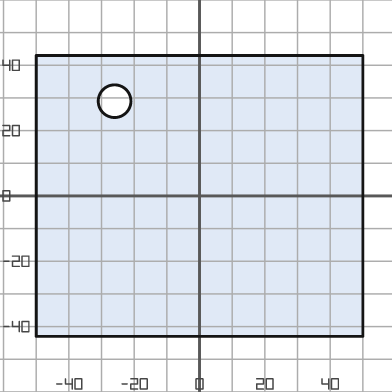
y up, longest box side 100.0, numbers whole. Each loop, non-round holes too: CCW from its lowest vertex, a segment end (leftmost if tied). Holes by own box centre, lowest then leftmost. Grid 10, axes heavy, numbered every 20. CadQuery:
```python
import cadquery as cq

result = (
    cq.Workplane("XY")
    .moveTo(-50.0, -43.0)
    .lineTo(50.0, -43.0)
    .lineTo(50.0, 43.0)
    .lineTo(-50.0, 43.0)
    .close()
    .moveTo(-26.0, 29.0)
    .circle(5.0)
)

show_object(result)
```